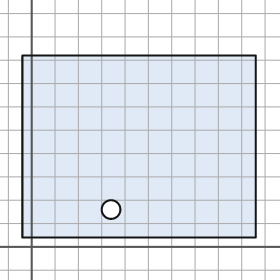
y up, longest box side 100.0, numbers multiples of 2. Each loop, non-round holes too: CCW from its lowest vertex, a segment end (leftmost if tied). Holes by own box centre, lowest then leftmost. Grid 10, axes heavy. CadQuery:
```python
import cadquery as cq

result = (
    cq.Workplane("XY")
    .moveTo(-4.0, 4.0)
    .lineTo(96.0, 4.0)
    .lineTo(96.0, 82.0)
    .lineTo(-4.0, 82.0)
    .close()
    .moveTo(34.0, 16.0)
    .circle(4.0)
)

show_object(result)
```